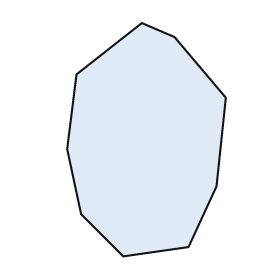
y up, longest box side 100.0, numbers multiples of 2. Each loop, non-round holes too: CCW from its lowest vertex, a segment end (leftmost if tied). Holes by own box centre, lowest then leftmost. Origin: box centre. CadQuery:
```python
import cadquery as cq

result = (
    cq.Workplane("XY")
    .moveTo(-10.0, -50.0)
    .lineTo(18.0, -46.0)
    .lineTo(30.0, -20.0)
    .lineTo(34.0, 18.0)
    .lineTo(12.0, 44.0)
    .lineTo(-2.0, 50.0)
    .lineTo(-30.0, 28.0)
    .lineTo(-34.0, -4.0)
    .lineTo(-28.0, -32.0)
    .close()
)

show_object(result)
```